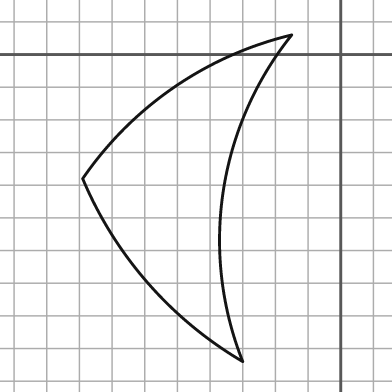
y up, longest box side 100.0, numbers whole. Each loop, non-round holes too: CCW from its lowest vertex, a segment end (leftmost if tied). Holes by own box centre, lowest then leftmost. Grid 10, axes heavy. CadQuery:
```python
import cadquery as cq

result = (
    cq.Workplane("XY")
    .moveTo(-30.0, -94.0)
    .threePointArc((-36.0, -42.0), (-15.0, 6.0))
    .threePointArc((-51.0, -10.0), (-79.0, -38.0))
    .threePointArc((-59.0, -70.0), (-30.0, -94.0))
    .close()
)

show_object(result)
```